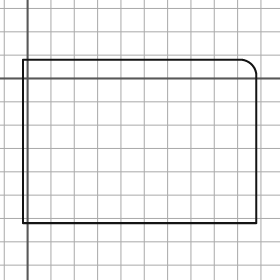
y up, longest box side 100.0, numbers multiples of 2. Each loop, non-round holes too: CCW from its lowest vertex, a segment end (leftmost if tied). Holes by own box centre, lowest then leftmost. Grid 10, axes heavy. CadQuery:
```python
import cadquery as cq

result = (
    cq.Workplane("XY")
    .moveTo(-2.0, -62.0)
    .lineTo(98.0, -62.0)
    .lineTo(98.0, 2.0)
    .threePointArc((96.0, 6.0), (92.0, 8.0))
    .lineTo(-2.0, 8.0)
    .close()
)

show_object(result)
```